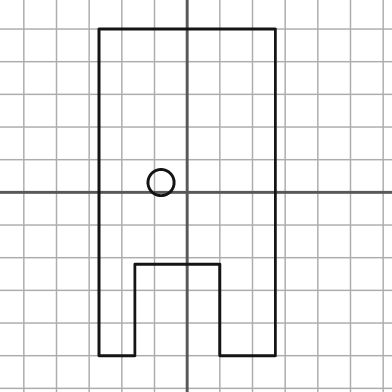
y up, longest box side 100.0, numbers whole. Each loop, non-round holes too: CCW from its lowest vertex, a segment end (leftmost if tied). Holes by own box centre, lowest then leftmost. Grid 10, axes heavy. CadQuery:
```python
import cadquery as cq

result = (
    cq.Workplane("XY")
    .moveTo(-27.0, -50.0)
    .lineTo(-16.0, -50.0)
    .lineTo(-16.0, -22.0)
    .lineTo(10.0, -22.0)
    .lineTo(10.0, -50.0)
    .lineTo(27.0, -50.0)
    .lineTo(27.0, 50.0)
    .lineTo(-27.0, 50.0)
    .close()
    .moveTo(-8.0, 3.0)
    .circle(4.0)
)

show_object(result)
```